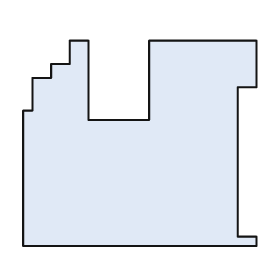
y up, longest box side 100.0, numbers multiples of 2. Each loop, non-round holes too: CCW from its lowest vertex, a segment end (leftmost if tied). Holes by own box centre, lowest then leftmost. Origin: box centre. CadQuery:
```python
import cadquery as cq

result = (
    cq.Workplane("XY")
    .moveTo(-50.0, -44.0)
    .lineTo(50.0, -44.0)
    .lineTo(50.0, -40.0)
    .lineTo(42.0, -40.0)
    .lineTo(42.0, 24.0)
    .lineTo(50.0, 24.0)
    .lineTo(50.0, 44.0)
    .lineTo(4.0, 44.0)
    .lineTo(4.0, 10.0)
    .lineTo(-22.0, 10.0)
    .lineTo(-22.0, 44.0)
    .lineTo(-30.0, 44.0)
    .lineTo(-30.0, 34.0)
    .lineTo(-38.0, 34.0)
    .lineTo(-38.0, 28.0)
    .lineTo(-46.0, 28.0)
    .lineTo(-46.0, 14.0)
    .lineTo(-50.0, 14.0)
    .close()
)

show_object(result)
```